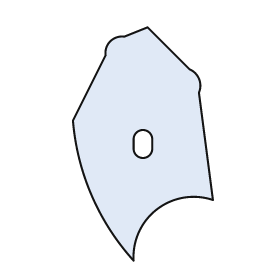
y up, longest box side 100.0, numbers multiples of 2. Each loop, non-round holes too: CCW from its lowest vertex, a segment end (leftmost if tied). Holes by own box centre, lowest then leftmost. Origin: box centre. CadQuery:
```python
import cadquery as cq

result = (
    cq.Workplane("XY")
    .moveTo(-4.0, -50.0)
    .threePointArc((6.0, -28.0), (30.0, -24.0))
    .lineTo(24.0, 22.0)
    .threePointArc((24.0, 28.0), (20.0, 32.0))
    .lineTo(2.0, 50.0)
    .lineTo(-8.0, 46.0)
    .threePointArc((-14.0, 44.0), (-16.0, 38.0))
    .lineTo(-30.0, 10.0)
    .threePointArc((-22.0, -22.0), (-4.0, -50.0))
    .close()
    .moveTo(-4.0, -2.0)
    .threePointArc((0.0, -6.0), (4.0, -2.0))
    .lineTo(4.0, 2.0)
    .threePointArc((0.0, 6.0), (-4.0, 2.0))
    .close()
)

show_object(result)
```